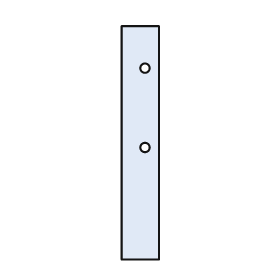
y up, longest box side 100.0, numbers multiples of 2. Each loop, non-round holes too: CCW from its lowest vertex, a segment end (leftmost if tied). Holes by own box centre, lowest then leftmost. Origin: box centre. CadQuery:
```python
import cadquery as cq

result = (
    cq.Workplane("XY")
    .moveTo(-8.0, -50.0)
    .lineTo(8.0, -50.0)
    .lineTo(8.0, 50.0)
    .lineTo(-8.0, 50.0)
    .close()
    .moveTo(2.0, -2.0)
    .circle(2.0)
    .moveTo(2.0, 32.0)
    .circle(2.0)
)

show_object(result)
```